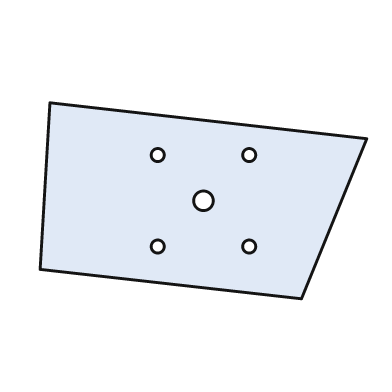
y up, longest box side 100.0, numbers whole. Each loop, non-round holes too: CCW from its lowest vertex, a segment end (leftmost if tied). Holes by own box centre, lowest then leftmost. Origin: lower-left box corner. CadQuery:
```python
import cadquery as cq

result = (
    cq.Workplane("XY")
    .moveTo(80.0, 0.0)
    .lineTo(100.0, 49.0)
    .lineTo(3.0, 60.0)
    .lineTo(0.0, 9.0)
    .close()
    .moveTo(36.0, 16.0)
    .circle(2.0)
    .moveTo(64.0, 16.0)
    .circle(2.0)
    .moveTo(50.0, 30.0)
    .circle(3.0)
    .moveTo(36.0, 44.0)
    .circle(2.0)
    .moveTo(64.0, 44.0)
    .circle(2.0)
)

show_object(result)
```